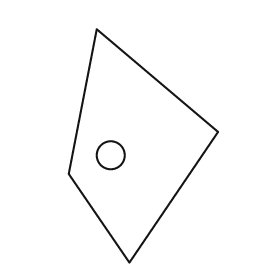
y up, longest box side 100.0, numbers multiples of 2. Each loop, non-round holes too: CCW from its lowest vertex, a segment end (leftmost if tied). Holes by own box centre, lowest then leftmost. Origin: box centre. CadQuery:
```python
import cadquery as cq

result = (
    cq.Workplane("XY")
    .moveTo(-6.0, -50.0)
    .lineTo(32.0, 6.0)
    .lineTo(-20.0, 50.0)
    .lineTo(-32.0, -12.0)
    .close()
    .moveTo(-14.0, -4.0)
    .circle(6.0)
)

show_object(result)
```